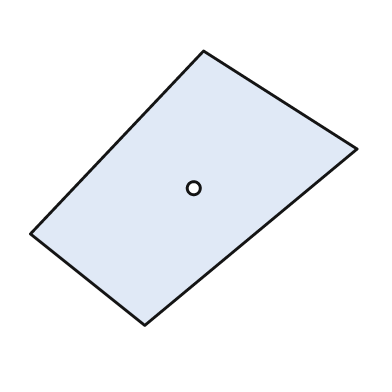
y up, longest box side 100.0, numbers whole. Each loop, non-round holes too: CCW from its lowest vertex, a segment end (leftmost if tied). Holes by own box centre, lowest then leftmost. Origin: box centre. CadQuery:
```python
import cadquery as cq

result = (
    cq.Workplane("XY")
    .moveTo(-15.0, -42.0)
    .lineTo(50.0, 12.0)
    .lineTo(3.0, 42.0)
    .lineTo(-50.0, -14.0)
    .close()
    .moveTo(0.0, 0.0)
    .circle(2.0)
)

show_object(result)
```